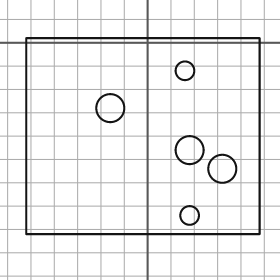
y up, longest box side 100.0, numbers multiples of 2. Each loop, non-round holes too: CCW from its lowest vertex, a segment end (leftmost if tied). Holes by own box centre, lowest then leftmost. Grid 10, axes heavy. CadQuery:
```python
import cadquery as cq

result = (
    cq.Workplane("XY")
    .moveTo(-52.0, -82.0)
    .lineTo(48.0, -82.0)
    .lineTo(48.0, 2.0)
    .lineTo(-52.0, 2.0)
    .close()
    .moveTo(18.0, -74.0)
    .circle(4.0)
    .moveTo(32.0, -54.0)
    .circle(6.0)
    .moveTo(18.0, -46.0)
    .circle(6.0)
    .moveTo(-16.0, -28.0)
    .circle(6.0)
    .moveTo(16.0, -12.0)
    .circle(4.0)
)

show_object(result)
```